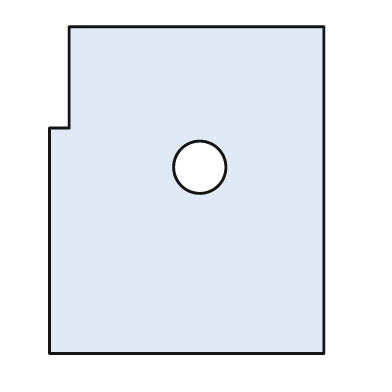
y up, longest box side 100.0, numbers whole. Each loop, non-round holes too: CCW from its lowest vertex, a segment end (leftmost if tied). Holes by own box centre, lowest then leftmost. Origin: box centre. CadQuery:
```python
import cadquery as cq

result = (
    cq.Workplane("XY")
    .moveTo(-42.0, -50.0)
    .lineTo(42.0, -50.0)
    .lineTo(42.0, 50.0)
    .lineTo(-36.0, 50.0)
    .lineTo(-36.0, 19.0)
    .lineTo(-42.0, 19.0)
    .close()
    .moveTo(4.0, 7.0)
    .circle(8.0)
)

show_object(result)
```